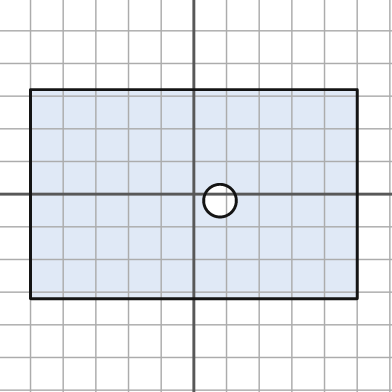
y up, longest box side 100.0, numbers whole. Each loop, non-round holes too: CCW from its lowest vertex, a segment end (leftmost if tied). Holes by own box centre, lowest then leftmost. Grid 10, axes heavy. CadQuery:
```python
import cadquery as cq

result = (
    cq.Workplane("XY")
    .moveTo(-50.0, -32.0)
    .lineTo(50.0, -32.0)
    .lineTo(50.0, 32.0)
    .lineTo(-50.0, 32.0)
    .close()
    .moveTo(8.0, -2.0)
    .circle(5.0)
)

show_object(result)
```